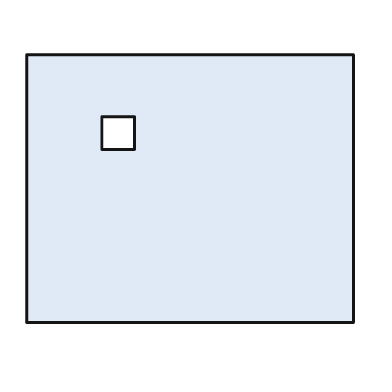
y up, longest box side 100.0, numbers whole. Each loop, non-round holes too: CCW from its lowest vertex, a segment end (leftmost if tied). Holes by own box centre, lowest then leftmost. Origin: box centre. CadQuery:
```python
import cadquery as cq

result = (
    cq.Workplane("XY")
    .moveTo(-50.0, -41.0)
    .lineTo(50.0, -41.0)
    .lineTo(50.0, 41.0)
    .lineTo(-50.0, 41.0)
    .close()
    .moveTo(-27.0, 12.0)
    .lineTo(-17.0, 12.0)
    .lineTo(-17.0, 22.0)
    .lineTo(-27.0, 22.0)
    .close()
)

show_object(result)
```